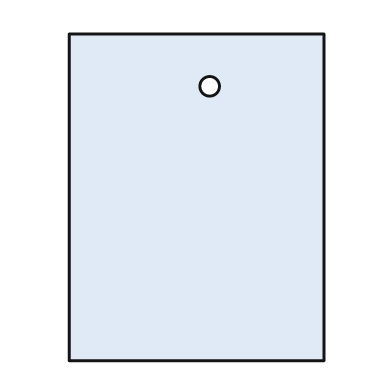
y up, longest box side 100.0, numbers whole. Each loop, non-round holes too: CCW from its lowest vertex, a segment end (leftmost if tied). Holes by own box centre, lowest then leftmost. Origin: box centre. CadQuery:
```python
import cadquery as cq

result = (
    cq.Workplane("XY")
    .moveTo(-39.0, -50.0)
    .lineTo(39.0, -50.0)
    .lineTo(39.0, 50.0)
    .lineTo(-39.0, 50.0)
    .close()
    .moveTo(4.0, 34.0)
    .circle(3.0)
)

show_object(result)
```